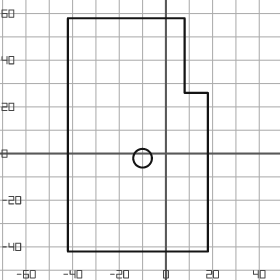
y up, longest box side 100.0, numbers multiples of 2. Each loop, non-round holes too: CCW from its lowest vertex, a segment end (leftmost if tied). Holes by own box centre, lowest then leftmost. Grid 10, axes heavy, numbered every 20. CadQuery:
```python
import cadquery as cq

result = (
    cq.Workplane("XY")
    .moveTo(-42.0, -42.0)
    .lineTo(18.0, -42.0)
    .lineTo(18.0, 26.0)
    .lineTo(8.0, 26.0)
    .lineTo(8.0, 58.0)
    .lineTo(-42.0, 58.0)
    .close()
    .moveTo(-10.0, -2.0)
    .circle(4.0)
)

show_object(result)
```